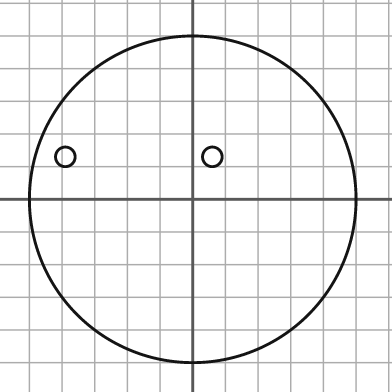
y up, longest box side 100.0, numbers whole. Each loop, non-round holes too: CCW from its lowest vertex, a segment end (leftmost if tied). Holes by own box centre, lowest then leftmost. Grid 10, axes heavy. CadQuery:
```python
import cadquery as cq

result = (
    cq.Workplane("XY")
    .moveTo(0.0, 0.0)
    .circle(50.0)
    .moveTo(-39.0, 13.0)
    .circle(3.0)
    .moveTo(6.0, 13.0)
    .circle(3.0)
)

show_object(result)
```